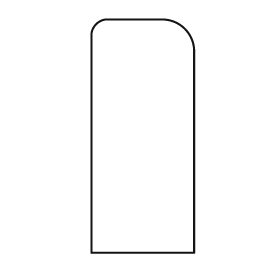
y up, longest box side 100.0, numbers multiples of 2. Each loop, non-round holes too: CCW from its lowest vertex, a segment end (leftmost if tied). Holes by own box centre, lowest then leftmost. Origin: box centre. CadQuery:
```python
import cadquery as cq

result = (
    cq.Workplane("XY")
    .moveTo(-22.0, -50.0)
    .lineTo(22.0, -50.0)
    .lineTo(22.0, 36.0)
    .threePointArc((18.0, 46.0), (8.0, 50.0))
    .lineTo(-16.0, 50.0)
    .threePointArc((-20.0, 48.0), (-22.0, 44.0))
    .close()
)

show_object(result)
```